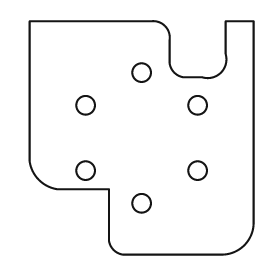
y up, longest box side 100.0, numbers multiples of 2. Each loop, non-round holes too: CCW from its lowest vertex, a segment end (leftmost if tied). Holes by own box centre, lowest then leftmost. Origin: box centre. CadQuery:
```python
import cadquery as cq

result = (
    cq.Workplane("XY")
    .moveTo(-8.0, -50.0)
    .lineTo(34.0, -50.0)
    .threePointArc((44.0, -46.0), (48.0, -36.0))
    .lineTo(48.0, 50.0)
    .lineTo(36.0, 50.0)
    .lineTo(36.0, 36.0)
    .threePointArc((34.0, 28.0), (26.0, 26.0))
    .lineTo(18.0, 26.0)
    .threePointArc((14.0, 28.0), (12.0, 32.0))
    .lineTo(12.0, 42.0)
    .threePointArc((10.0, 48.0), (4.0, 50.0))
    .lineTo(-48.0, 50.0)
    .lineTo(-48.0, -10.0)
    .threePointArc((-44.0, -18.0), (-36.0, -22.0))
    .lineTo(-14.0, -22.0)
    .lineTo(-14.0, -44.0)
    .threePointArc((-12.0, -48.0), (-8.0, -50.0))
    .close()
    .moveTo(0.0, -28.0)
    .circle(4.0)
    .moveTo(-24.0, -14.0)
    .circle(4.0)
    .moveTo(24.0, -14.0)
    .circle(4.0)
    .moveTo(-24.0, 14.0)
    .circle(4.0)
    .moveTo(24.0, 14.0)
    .circle(4.0)
    .moveTo(0.0, 28.0)
    .circle(4.0)
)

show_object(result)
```